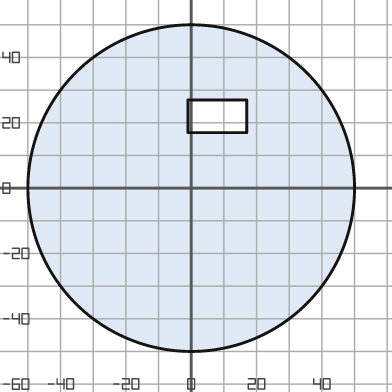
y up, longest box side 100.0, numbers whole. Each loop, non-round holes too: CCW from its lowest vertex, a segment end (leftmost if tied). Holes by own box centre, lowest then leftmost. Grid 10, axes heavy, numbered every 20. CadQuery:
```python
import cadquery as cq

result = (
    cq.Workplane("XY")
    .moveTo(0.0, 0.0)
    .circle(50.0)
    .moveTo(-1.0, 17.0)
    .lineTo(17.0, 17.0)
    .lineTo(17.0, 27.0)
    .lineTo(-1.0, 27.0)
    .close()
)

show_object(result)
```